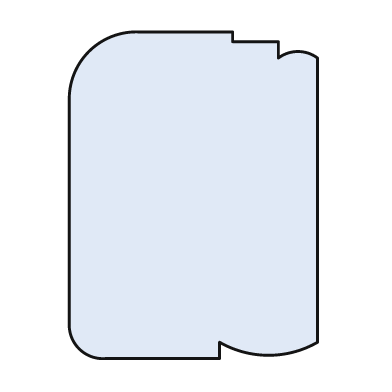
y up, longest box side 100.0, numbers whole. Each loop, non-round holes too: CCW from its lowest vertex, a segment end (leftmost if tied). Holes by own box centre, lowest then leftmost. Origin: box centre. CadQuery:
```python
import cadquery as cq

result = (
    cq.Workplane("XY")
    .moveTo(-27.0, -50.0)
    .lineTo(8.0, -50.0)
    .lineTo(8.0, -45.0)
    .threePointArc((23.0, -49.0), (38.0, -45.0))
    .lineTo(38.0, 42.0)
    .threePointArc((32.0, 44.0), (26.0, 42.0))
    .lineTo(26.0, 47.0)
    .lineTo(12.0, 47.0)
    .lineTo(12.0, 50.0)
    .lineTo(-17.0, 50.0)
    .threePointArc((-32.0, 44.0), (-38.0, 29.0))
    .lineTo(-38.0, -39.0)
    .threePointArc((-35.0, -47.0), (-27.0, -50.0))
    .close()
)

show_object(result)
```